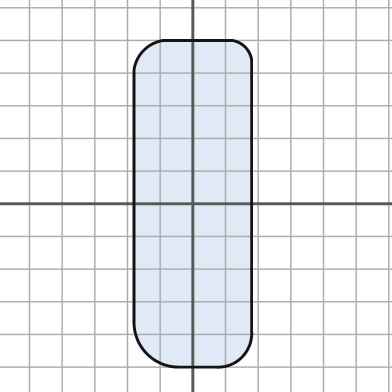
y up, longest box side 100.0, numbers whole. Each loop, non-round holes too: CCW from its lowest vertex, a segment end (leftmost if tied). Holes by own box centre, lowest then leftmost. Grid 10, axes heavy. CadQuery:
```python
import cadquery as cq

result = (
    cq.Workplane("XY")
    .moveTo(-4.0, -50.0)
    .lineTo(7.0, -50.0)
    .threePointArc((15.0, -47.0), (18.0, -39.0))
    .lineTo(18.0, 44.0)
    .threePointArc((16.0, 48.0), (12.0, 50.0))
    .lineTo(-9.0, 50.0)
    .threePointArc((-15.0, 47.0), (-18.0, 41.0))
    .lineTo(-18.0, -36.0)
    .threePointArc((-14.0, -46.0), (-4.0, -50.0))
    .close()
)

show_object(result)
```